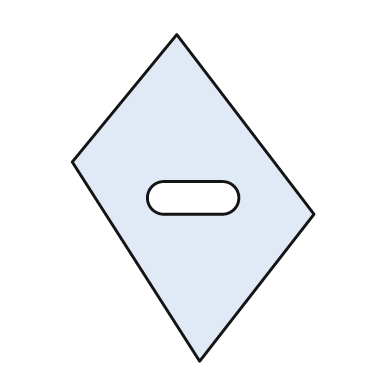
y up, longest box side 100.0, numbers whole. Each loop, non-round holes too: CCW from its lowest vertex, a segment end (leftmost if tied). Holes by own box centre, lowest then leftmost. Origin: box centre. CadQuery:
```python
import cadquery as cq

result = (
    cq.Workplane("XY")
    .moveTo(2.0, -50.0)
    .lineTo(37.0, -5.0)
    .lineTo(-5.0, 50.0)
    .lineTo(-37.0, 11.0)
    .close()
    .moveTo(-9.0, -5.0)
    .lineTo(9.0, -5.0)
    .threePointArc((14.0, 0.0), (9.0, 5.0))
    .lineTo(-9.0, 5.0)
    .threePointArc((-14.0, 0.0), (-9.0, -5.0))
    .close()
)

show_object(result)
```